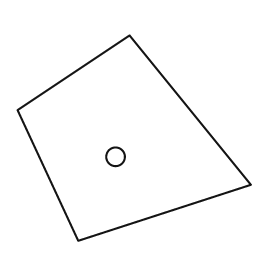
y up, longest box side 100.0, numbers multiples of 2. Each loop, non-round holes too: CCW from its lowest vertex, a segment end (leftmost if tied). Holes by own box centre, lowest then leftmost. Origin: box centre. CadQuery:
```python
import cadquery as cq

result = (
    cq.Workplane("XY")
    .moveTo(-24.0, -44.0)
    .lineTo(50.0, -20.0)
    .lineTo(-2.0, 44.0)
    .lineTo(-50.0, 12.0)
    .close()
    .moveTo(-8.0, -8.0)
    .circle(4.0)
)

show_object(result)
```